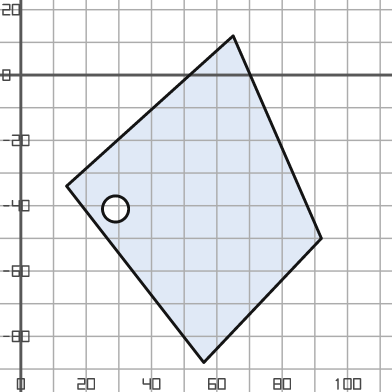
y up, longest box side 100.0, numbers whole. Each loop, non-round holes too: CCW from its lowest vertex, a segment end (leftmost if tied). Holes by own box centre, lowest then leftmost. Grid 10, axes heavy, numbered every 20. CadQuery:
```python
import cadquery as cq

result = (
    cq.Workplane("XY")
    .moveTo(56.0, -88.0)
    .lineTo(92.0, -50.0)
    .lineTo(65.0, 12.0)
    .lineTo(14.0, -34.0)
    .close()
    .moveTo(29.0, -41.0)
    .circle(4.0)
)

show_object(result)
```